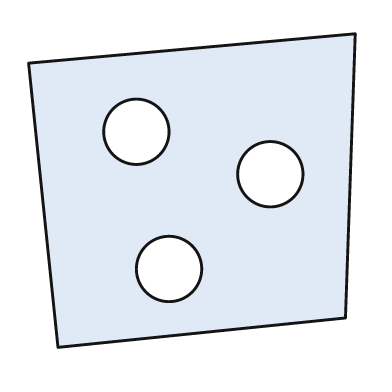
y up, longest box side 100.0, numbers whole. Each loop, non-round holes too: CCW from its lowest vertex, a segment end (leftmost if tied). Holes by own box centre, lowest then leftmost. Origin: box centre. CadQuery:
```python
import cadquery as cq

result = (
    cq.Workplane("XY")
    .moveTo(-41.0, -48.0)
    .lineTo(47.0, -39.0)
    .lineTo(50.0, 48.0)
    .lineTo(-50.0, 39.0)
    .close()
    .moveTo(-7.0, -24.0)
    .circle(10.0)
    .moveTo(24.0, 5.0)
    .circle(10.0)
    .moveTo(-17.0, 18.0)
    .circle(10.0)
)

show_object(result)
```